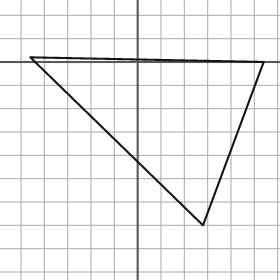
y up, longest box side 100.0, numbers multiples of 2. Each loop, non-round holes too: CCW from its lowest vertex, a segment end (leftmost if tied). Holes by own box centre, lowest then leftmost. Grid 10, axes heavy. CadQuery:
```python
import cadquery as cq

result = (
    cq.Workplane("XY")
    .moveTo(28.0, -70.0)
    .lineTo(54.0, 0.0)
    .lineTo(-46.0, 2.0)
    .close()
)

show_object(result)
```